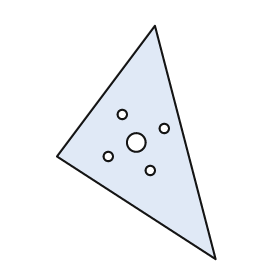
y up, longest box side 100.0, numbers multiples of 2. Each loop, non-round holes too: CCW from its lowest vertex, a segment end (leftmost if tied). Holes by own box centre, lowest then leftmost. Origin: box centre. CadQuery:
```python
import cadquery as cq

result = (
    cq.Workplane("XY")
    .moveTo(34.0, -50.0)
    .lineTo(8.0, 50.0)
    .lineTo(-34.0, -6.0)
    .close()
    .moveTo(6.0, -12.0)
    .circle(2.0)
    .moveTo(-12.0, -6.0)
    .circle(2.0)
    .moveTo(0.0, 0.0)
    .circle(4.0)
    .moveTo(12.0, 6.0)
    .circle(2.0)
    .moveTo(-6.0, 12.0)
    .circle(2.0)
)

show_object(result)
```